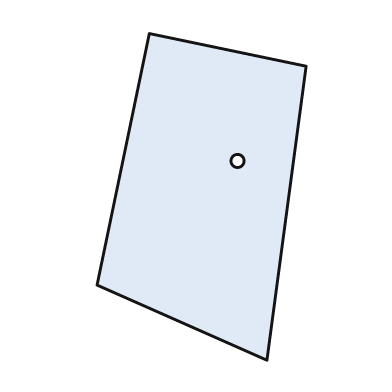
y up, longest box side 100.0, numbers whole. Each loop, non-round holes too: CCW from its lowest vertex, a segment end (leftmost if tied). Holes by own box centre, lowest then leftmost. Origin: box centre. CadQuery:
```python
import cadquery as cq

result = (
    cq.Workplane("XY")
    .moveTo(20.0, -50.0)
    .lineTo(32.0, 40.0)
    .lineTo(-16.0, 50.0)
    .lineTo(-32.0, -27.0)
    .close()
    .moveTo(11.0, 11.0)
    .circle(2.0)
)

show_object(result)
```